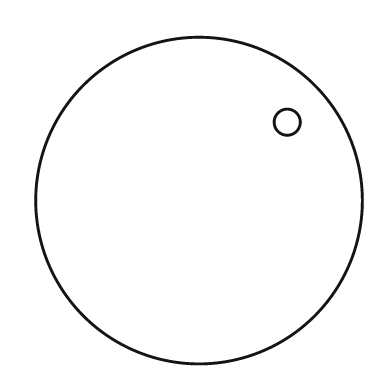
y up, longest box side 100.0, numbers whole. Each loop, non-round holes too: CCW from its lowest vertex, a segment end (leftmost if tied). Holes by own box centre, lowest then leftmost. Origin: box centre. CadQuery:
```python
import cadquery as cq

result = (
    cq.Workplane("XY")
    .moveTo(0.0, 0.0)
    .circle(50.0)
    .moveTo(27.0, 24.0)
    .circle(4.0)
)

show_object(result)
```